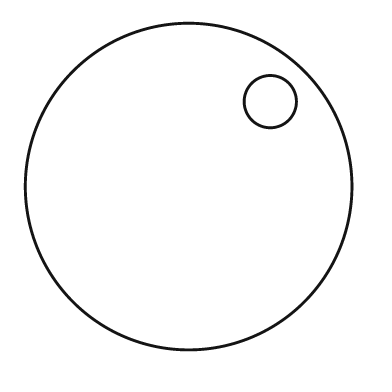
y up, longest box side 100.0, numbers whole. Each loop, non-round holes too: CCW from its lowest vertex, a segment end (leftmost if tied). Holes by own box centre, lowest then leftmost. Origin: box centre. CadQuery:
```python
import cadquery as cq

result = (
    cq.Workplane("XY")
    .moveTo(0.0, 0.0)
    .circle(50.0)
    .moveTo(25.0, 26.0)
    .circle(8.0)
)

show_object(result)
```